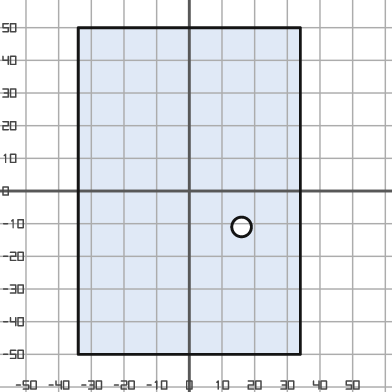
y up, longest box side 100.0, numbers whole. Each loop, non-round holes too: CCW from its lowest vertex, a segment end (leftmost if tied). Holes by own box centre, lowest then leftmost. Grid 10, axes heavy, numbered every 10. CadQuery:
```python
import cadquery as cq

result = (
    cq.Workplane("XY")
    .moveTo(-34.0, -50.0)
    .lineTo(34.0, -50.0)
    .lineTo(34.0, 50.0)
    .lineTo(-34.0, 50.0)
    .close()
    .moveTo(16.0, -11.0)
    .circle(3.0)
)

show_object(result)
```